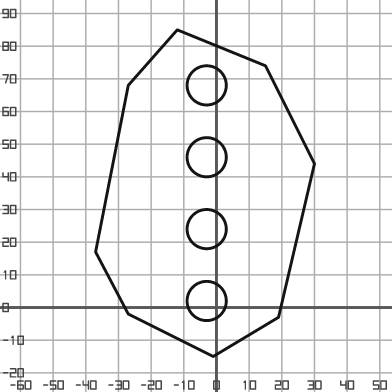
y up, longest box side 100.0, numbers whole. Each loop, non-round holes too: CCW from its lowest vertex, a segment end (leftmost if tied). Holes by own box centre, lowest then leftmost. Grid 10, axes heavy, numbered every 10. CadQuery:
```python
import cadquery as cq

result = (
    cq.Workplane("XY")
    .moveTo(-1.0, -15.0)
    .lineTo(19.0, -3.0)
    .lineTo(30.0, 44.0)
    .lineTo(15.0, 74.0)
    .lineTo(-12.0, 85.0)
    .lineTo(-27.0, 68.0)
    .lineTo(-37.0, 17.0)
    .lineTo(-27.0, -2.0)
    .close()
    .moveTo(-3.0, 2.0)
    .circle(6.0)
    .moveTo(-3.0, 24.0)
    .circle(6.0)
    .moveTo(-3.0, 46.0)
    .circle(6.0)
    .moveTo(-3.0, 68.0)
    .circle(6.0)
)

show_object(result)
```